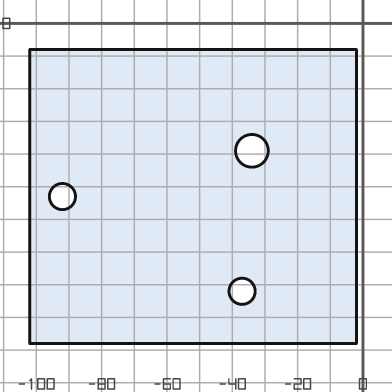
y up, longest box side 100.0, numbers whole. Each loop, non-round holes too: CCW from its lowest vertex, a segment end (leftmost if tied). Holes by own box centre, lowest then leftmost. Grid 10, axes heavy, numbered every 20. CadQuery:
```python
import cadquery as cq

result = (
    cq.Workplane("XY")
    .moveTo(-102.0, -98.0)
    .lineTo(-2.0, -98.0)
    .lineTo(-2.0, -8.0)
    .lineTo(-102.0, -8.0)
    .close()
    .moveTo(-37.0, -82.0)
    .circle(4.0)
    .moveTo(-92.0, -53.0)
    .circle(4.0)
    .moveTo(-34.0, -39.0)
    .circle(5.0)
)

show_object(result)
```